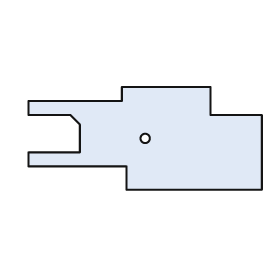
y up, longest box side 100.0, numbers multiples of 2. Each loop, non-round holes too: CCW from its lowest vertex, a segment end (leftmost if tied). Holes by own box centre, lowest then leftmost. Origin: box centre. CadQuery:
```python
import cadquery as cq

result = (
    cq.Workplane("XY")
    .moveTo(-8.0, -22.0)
    .lineTo(50.0, -22.0)
    .lineTo(50.0, 10.0)
    .lineTo(28.0, 10.0)
    .lineTo(28.0, 22.0)
    .lineTo(-10.0, 22.0)
    .lineTo(-10.0, 16.0)
    .lineTo(-50.0, 16.0)
    .lineTo(-50.0, 10.0)
    .lineTo(-32.0, 10.0)
    .lineTo(-28.0, 6.0)
    .lineTo(-28.0, -6.0)
    .lineTo(-50.0, -6.0)
    .lineTo(-50.0, -12.0)
    .lineTo(-8.0, -12.0)
    .close()
    .moveTo(0.0, 0.0)
    .circle(2.0)
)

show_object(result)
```